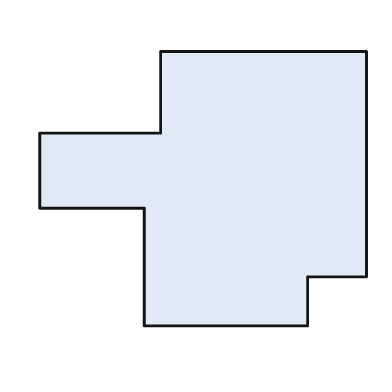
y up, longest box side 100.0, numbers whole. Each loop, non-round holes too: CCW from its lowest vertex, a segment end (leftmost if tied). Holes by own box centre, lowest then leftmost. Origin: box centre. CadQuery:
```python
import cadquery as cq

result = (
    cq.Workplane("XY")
    .moveTo(-18.0, -42.0)
    .lineTo(32.0, -42.0)
    .lineTo(32.0, -27.0)
    .lineTo(50.0, -27.0)
    .lineTo(50.0, 42.0)
    .lineTo(-13.0, 42.0)
    .lineTo(-13.0, 17.0)
    .lineTo(-50.0, 17.0)
    .lineTo(-50.0, -6.0)
    .lineTo(-18.0, -6.0)
    .close()
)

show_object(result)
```